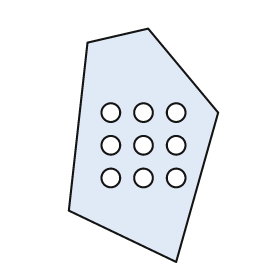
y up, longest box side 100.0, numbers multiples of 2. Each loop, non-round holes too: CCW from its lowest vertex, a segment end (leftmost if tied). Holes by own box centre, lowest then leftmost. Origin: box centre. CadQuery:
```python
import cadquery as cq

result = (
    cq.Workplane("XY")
    .moveTo(14.0, -50.0)
    .lineTo(32.0, 14.0)
    .lineTo(2.0, 50.0)
    .lineTo(-24.0, 44.0)
    .lineTo(-32.0, -28.0)
    .close()
    .moveTo(-14.0, -14.0)
    .circle(4.0)
    .moveTo(0.0, -14.0)
    .circle(4.0)
    .moveTo(14.0, -14.0)
    .circle(4.0)
    .moveTo(-14.0, 0.0)
    .circle(4.0)
    .moveTo(0.0, 0.0)
    .circle(4.0)
    .moveTo(14.0, 0.0)
    .circle(4.0)
    .moveTo(-14.0, 14.0)
    .circle(4.0)
    .moveTo(0.0, 14.0)
    .circle(4.0)
    .moveTo(14.0, 14.0)
    .circle(4.0)
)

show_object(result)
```